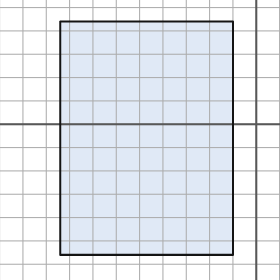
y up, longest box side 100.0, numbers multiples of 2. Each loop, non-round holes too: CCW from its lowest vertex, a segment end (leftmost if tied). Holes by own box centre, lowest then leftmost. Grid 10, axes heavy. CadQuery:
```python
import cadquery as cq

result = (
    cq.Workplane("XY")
    .moveTo(-84.0, -56.0)
    .lineTo(-10.0, -56.0)
    .lineTo(-10.0, 44.0)
    .lineTo(-84.0, 44.0)
    .close()
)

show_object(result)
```